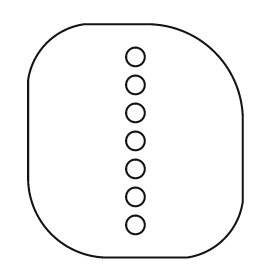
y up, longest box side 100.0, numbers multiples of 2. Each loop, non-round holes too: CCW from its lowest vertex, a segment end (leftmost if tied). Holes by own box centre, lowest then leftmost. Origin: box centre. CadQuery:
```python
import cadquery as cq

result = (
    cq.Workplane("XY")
    .moveTo(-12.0, -50.0)
    .lineTo(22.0, -50.0)
    .threePointArc((38.0, -42.0), (46.0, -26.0))
    .lineTo(46.0, 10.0)
    .threePointArc((34.0, 38.0), (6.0, 50.0))
    .lineTo(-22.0, 50.0)
    .threePointArc((-38.0, 42.0), (-46.0, 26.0))
    .lineTo(-46.0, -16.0)
    .threePointArc((-36.0, -40.0), (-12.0, -50.0))
    .close()
    .moveTo(0.0, -36.0)
    .circle(4.0)
    .moveTo(0.0, -24.0)
    .circle(4.0)
    .moveTo(0.0, -12.0)
    .circle(4.0)
    .moveTo(0.0, 0.0)
    .circle(4.0)
    .moveTo(0.0, 12.0)
    .circle(4.0)
    .moveTo(0.0, 24.0)
    .circle(4.0)
    .moveTo(0.0, 36.0)
    .circle(4.0)
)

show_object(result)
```